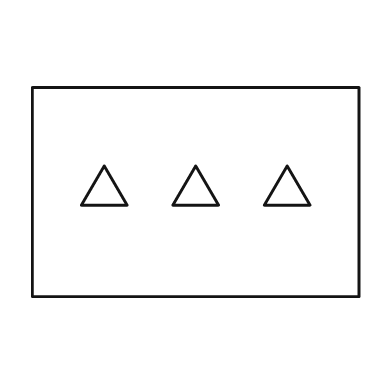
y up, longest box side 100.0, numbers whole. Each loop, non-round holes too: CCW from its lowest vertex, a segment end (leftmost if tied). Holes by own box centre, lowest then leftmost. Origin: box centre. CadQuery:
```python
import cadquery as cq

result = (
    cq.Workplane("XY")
    .moveTo(-50.0, -32.0)
    .lineTo(50.0, -32.0)
    .lineTo(50.0, 32.0)
    .lineTo(-50.0, 32.0)
    .close()
    .moveTo(-35.0, -4.0)
    .lineTo(-21.0, -4.0)
    .lineTo(-28.0, 8.0)
    .close()
    .moveTo(-7.0, -4.0)
    .lineTo(7.0, -4.0)
    .lineTo(0.0, 8.0)
    .close()
    .moveTo(21.0, -4.0)
    .lineTo(35.0, -4.0)
    .lineTo(28.0, 8.0)
    .close()
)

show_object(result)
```